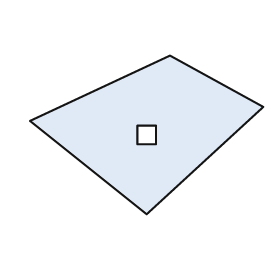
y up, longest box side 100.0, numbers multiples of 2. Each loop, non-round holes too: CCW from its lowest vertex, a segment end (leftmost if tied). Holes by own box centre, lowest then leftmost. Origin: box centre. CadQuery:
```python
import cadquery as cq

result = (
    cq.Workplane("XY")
    .moveTo(0.0, -34.0)
    .lineTo(50.0, 12.0)
    .lineTo(10.0, 34.0)
    .lineTo(-50.0, 6.0)
    .close()
    .moveTo(-4.0, -4.0)
    .lineTo(4.0, -4.0)
    .lineTo(4.0, 4.0)
    .lineTo(-4.0, 4.0)
    .close()
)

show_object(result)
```